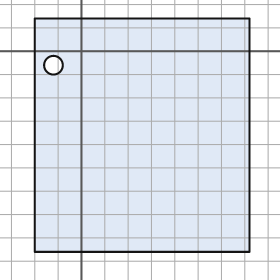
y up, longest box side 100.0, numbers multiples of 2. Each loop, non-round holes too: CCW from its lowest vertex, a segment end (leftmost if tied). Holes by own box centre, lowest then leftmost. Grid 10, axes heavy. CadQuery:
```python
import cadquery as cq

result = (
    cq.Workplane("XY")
    .moveTo(-20.0, -86.0)
    .lineTo(72.0, -86.0)
    .lineTo(72.0, 14.0)
    .lineTo(-20.0, 14.0)
    .close()
    .moveTo(-12.0, -6.0)
    .circle(4.0)
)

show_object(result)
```